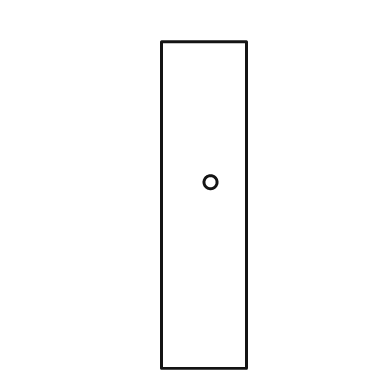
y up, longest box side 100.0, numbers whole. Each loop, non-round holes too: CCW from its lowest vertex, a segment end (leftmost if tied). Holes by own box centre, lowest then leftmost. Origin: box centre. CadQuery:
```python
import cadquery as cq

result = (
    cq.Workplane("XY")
    .moveTo(-13.0, -50.0)
    .lineTo(13.0, -50.0)
    .lineTo(13.0, 50.0)
    .lineTo(-13.0, 50.0)
    .close()
    .moveTo(2.0, 7.0)
    .circle(2.0)
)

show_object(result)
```